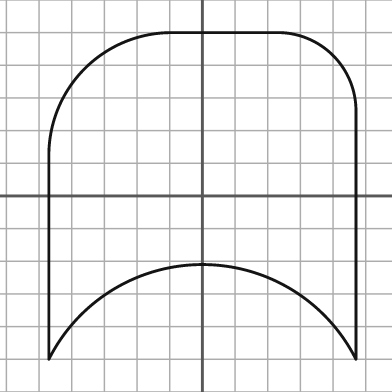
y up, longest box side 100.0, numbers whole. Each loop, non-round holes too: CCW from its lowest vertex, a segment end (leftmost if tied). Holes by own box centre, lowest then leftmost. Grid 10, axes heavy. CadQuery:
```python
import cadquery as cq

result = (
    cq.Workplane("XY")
    .moveTo(-47.0, -50.0)
    .threePointArc((0.0, -21.0), (47.0, -50.0))
    .lineTo(47.0, 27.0)
    .threePointArc((40.0, 43.0), (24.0, 50.0))
    .lineTo(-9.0, 50.0)
    .threePointArc((-36.0, 39.0), (-47.0, 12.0))
    .close()
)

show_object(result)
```